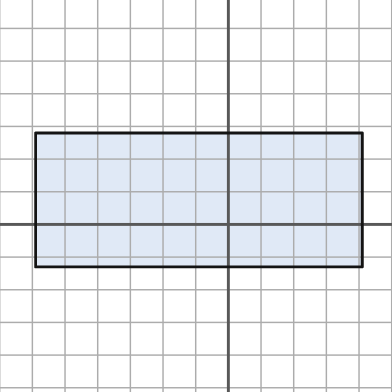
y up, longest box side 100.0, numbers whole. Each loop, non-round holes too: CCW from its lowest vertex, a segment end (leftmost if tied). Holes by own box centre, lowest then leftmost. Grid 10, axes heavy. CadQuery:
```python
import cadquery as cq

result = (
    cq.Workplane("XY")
    .moveTo(-59.0, -13.0)
    .lineTo(41.0, -13.0)
    .lineTo(41.0, 28.0)
    .lineTo(-59.0, 28.0)
    .close()
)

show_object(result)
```